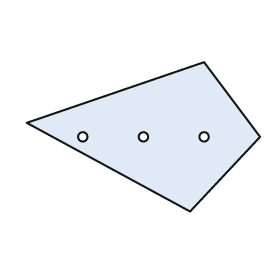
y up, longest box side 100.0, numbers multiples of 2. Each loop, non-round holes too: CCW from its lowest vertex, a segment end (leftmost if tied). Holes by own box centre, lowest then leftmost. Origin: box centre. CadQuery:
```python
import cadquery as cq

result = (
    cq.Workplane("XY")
    .moveTo(20.0, -32.0)
    .lineTo(50.0, 0.0)
    .lineTo(26.0, 32.0)
    .lineTo(-50.0, 6.0)
    .close()
    .moveTo(-26.0, 0.0)
    .circle(2.0)
    .moveTo(0.0, 0.0)
    .circle(2.0)
    .moveTo(26.0, 0.0)
    .circle(2.0)
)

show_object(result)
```